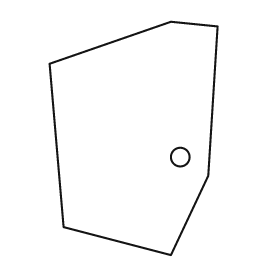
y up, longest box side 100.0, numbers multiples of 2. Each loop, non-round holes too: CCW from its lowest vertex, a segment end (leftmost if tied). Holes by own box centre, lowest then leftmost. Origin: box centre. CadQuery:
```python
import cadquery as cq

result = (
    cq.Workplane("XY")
    .moveTo(16.0, -50.0)
    .lineTo(32.0, -16.0)
    .lineTo(36.0, 48.0)
    .lineTo(16.0, 50.0)
    .lineTo(-36.0, 32.0)
    .lineTo(-30.0, -38.0)
    .close()
    .moveTo(20.0, -8.0)
    .circle(4.0)
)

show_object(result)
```